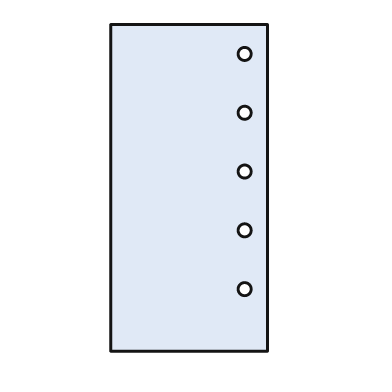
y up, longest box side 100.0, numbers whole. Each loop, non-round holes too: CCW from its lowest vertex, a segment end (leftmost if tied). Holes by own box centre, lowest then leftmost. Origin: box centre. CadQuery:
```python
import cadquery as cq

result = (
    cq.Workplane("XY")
    .moveTo(-24.0, -50.0)
    .lineTo(24.0, -50.0)
    .lineTo(24.0, 50.0)
    .lineTo(-24.0, 50.0)
    .close()
    .moveTo(17.0, -31.0)
    .circle(2.0)
    .moveTo(17.0, -13.0)
    .circle(2.0)
    .moveTo(17.0, 5.0)
    .circle(2.0)
    .moveTo(17.0, 23.0)
    .circle(2.0)
    .moveTo(17.0, 41.0)
    .circle(2.0)
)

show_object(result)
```